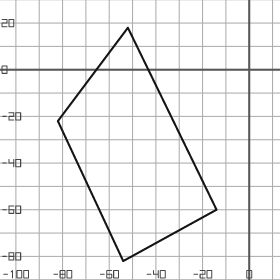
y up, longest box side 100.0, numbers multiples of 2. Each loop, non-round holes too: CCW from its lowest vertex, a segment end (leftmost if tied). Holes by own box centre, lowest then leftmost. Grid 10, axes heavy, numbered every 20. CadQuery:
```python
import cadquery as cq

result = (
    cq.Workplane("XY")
    .moveTo(-54.0, -82.0)
    .lineTo(-14.0, -60.0)
    .lineTo(-52.0, 18.0)
    .lineTo(-82.0, -22.0)
    .close()
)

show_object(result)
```